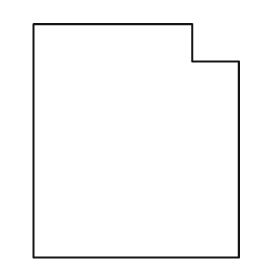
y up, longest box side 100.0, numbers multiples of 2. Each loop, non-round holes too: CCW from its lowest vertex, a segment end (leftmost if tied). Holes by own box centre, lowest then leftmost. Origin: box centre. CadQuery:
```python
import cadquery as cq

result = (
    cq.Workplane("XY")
    .moveTo(-44.0, -50.0)
    .lineTo(44.0, -50.0)
    .lineTo(44.0, 34.0)
    .lineTo(24.0, 34.0)
    .lineTo(24.0, 50.0)
    .lineTo(-44.0, 50.0)
    .close()
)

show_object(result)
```